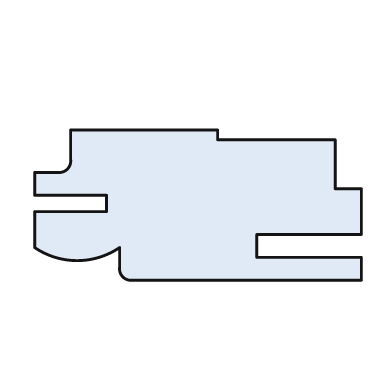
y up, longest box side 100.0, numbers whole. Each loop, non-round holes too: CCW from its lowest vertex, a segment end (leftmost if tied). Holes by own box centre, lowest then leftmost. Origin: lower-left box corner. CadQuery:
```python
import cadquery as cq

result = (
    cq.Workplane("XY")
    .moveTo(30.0, 0.0)
    .lineTo(100.0, 0.0)
    .lineTo(100.0, 7.0)
    .lineTo(68.0, 7.0)
    .lineTo(68.0, 14.0)
    .lineTo(100.0, 14.0)
    .lineTo(100.0, 28.0)
    .lineTo(92.0, 28.0)
    .lineTo(92.0, 43.0)
    .lineTo(56.0, 43.0)
    .lineTo(56.0, 46.0)
    .lineTo(11.0, 46.0)
    .lineTo(11.0, 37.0)
    .threePointArc((10.0, 34.0), (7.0, 33.0))
    .lineTo(0.0, 33.0)
    .lineTo(0.0, 26.0)
    .lineTo(22.0, 26.0)
    .lineTo(22.0, 21.0)
    .lineTo(0.0, 21.0)
    .lineTo(0.0, 10.0)
    .threePointArc((13.0, 6.0), (26.0, 10.0))
    .lineTo(26.0, 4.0)
    .threePointArc((27.0, 1.0), (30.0, 0.0))
    .close()
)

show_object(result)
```